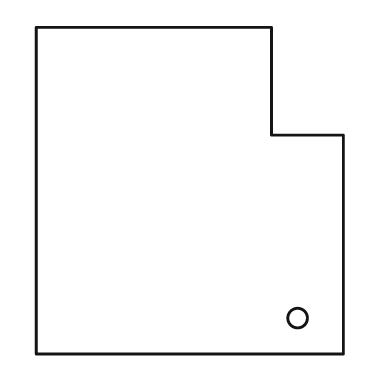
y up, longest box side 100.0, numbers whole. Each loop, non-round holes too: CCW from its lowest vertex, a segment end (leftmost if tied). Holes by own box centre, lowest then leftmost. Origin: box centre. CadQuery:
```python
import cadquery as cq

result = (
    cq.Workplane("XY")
    .moveTo(-47.0, -50.0)
    .lineTo(47.0, -50.0)
    .lineTo(47.0, 17.0)
    .lineTo(25.0, 17.0)
    .lineTo(25.0, 50.0)
    .lineTo(-47.0, 50.0)
    .close()
    .moveTo(33.0, -39.0)
    .circle(3.0)
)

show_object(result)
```